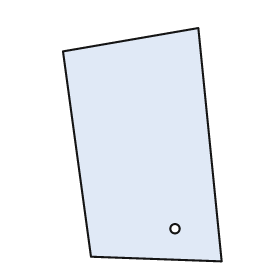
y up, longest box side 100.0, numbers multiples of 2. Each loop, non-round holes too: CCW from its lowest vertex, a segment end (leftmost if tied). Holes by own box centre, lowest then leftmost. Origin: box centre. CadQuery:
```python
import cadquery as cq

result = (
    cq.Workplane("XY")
    .moveTo(34.0, -50.0)
    .lineTo(24.0, 50.0)
    .lineTo(-34.0, 40.0)
    .lineTo(-22.0, -48.0)
    .close()
    .moveTo(14.0, -36.0)
    .circle(2.0)
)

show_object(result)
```